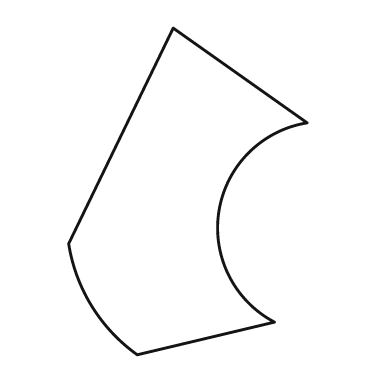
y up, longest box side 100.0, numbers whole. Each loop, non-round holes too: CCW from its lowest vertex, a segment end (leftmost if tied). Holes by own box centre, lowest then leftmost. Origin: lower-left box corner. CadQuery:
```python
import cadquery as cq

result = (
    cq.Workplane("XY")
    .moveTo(21.0, 0.0)
    .lineTo(63.0, 10.0)
    .threePointArc((46.0, 44.0), (73.0, 71.0))
    .lineTo(32.0, 100.0)
    .lineTo(0.0, 34.0)
    .threePointArc((7.0, 15.0), (21.0, 0.0))
    .close()
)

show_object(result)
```